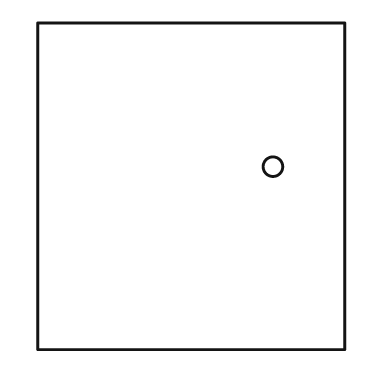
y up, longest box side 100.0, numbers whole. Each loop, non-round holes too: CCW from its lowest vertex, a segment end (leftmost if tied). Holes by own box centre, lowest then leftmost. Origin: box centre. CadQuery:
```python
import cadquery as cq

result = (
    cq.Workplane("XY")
    .moveTo(-47.0, -50.0)
    .lineTo(47.0, -50.0)
    .lineTo(47.0, 50.0)
    .lineTo(-47.0, 50.0)
    .close()
    .moveTo(25.0, 6.0)
    .circle(3.0)
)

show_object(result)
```